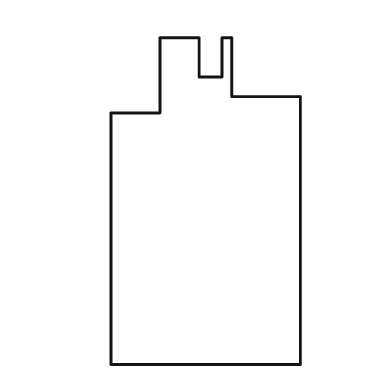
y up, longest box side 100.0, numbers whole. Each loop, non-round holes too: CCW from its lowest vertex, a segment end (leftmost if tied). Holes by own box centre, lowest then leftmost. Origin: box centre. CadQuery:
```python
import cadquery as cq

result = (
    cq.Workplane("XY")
    .moveTo(-29.0, -50.0)
    .lineTo(29.0, -50.0)
    .lineTo(29.0, 32.0)
    .lineTo(8.0, 32.0)
    .lineTo(8.0, 50.0)
    .lineTo(5.0, 50.0)
    .lineTo(5.0, 38.0)
    .lineTo(-2.0, 38.0)
    .lineTo(-2.0, 50.0)
    .lineTo(-14.0, 50.0)
    .lineTo(-14.0, 27.0)
    .lineTo(-29.0, 27.0)
    .close()
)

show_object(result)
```